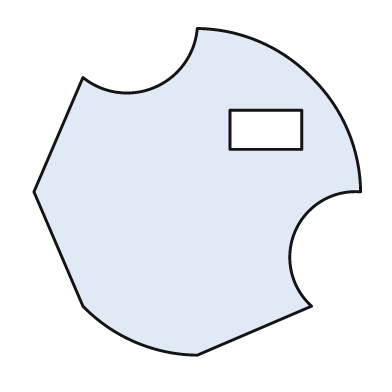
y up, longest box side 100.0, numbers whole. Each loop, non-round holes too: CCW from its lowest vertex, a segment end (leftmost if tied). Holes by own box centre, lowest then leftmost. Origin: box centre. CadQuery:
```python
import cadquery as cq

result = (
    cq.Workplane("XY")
    .moveTo(0.0, -50.0)
    .lineTo(35.0, -35.0)
    .threePointArc((30.0, -12.0), (50.0, 0.0))
    .threePointArc((46.0, 19.0), (35.0, 35.0))
    .threePointArc((19.0, 46.0), (0.0, 50.0))
    .threePointArc((-13.0, 32.0), (-35.0, 35.0))
    .lineTo(-50.0, 0.0)
    .lineTo(-35.0, -35.0)
    .threePointArc((-19.0, -46.0), (0.0, -50.0))
    .close()
    .moveTo(10.0, 13.0)
    .lineTo(32.0, 13.0)
    .lineTo(32.0, 25.0)
    .lineTo(10.0, 25.0)
    .close()
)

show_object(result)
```